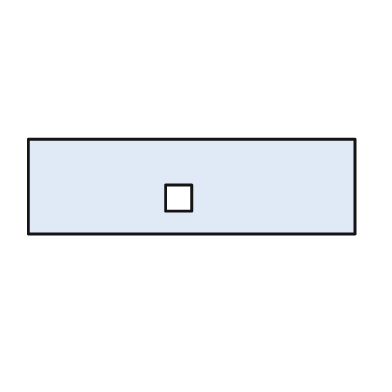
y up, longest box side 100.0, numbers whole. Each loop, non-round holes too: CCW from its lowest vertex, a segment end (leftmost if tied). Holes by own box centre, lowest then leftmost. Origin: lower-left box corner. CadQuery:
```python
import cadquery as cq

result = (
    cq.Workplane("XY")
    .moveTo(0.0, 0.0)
    .lineTo(100.0, 0.0)
    .lineTo(100.0, 29.0)
    .lineTo(0.0, 29.0)
    .close()
    .moveTo(42.0, 7.0)
    .lineTo(50.0, 7.0)
    .lineTo(50.0, 15.0)
    .lineTo(42.0, 15.0)
    .close()
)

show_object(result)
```